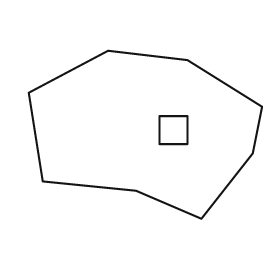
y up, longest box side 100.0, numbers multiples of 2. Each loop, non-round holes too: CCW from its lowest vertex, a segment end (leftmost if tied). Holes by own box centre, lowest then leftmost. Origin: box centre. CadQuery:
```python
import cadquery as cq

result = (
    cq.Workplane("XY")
    .moveTo(24.0, -36.0)
    .lineTo(46.0, -8.0)
    .lineTo(50.0, 12.0)
    .lineTo(18.0, 32.0)
    .lineTo(-16.0, 36.0)
    .lineTo(-50.0, 18.0)
    .lineTo(-44.0, -20.0)
    .lineTo(-4.0, -24.0)
    .close()
    .moveTo(6.0, -4.0)
    .lineTo(18.0, -4.0)
    .lineTo(18.0, 8.0)
    .lineTo(6.0, 8.0)
    .close()
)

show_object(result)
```